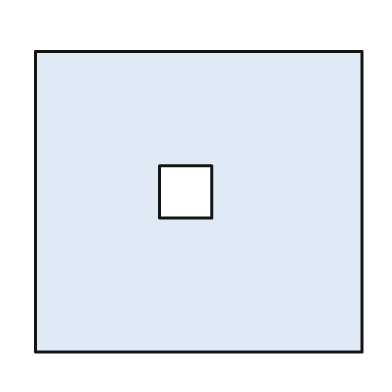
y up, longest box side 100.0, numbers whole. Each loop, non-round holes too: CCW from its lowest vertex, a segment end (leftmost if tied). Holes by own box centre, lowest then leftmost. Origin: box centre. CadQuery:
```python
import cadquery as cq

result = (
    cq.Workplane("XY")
    .moveTo(-50.0, -46.0)
    .lineTo(50.0, -46.0)
    .lineTo(50.0, 46.0)
    .lineTo(-50.0, 46.0)
    .close()
    .moveTo(-12.0, -5.0)
    .lineTo(4.0, -5.0)
    .lineTo(4.0, 11.0)
    .lineTo(-12.0, 11.0)
    .close()
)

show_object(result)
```